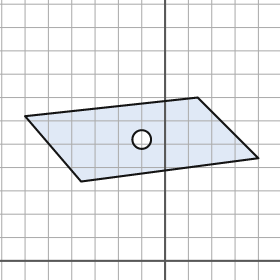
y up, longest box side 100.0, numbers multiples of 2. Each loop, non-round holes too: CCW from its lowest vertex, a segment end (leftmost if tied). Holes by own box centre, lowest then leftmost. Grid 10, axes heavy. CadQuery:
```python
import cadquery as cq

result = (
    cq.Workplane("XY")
    .moveTo(-36.0, 34.0)
    .lineTo(40.0, 44.0)
    .lineTo(14.0, 70.0)
    .lineTo(-60.0, 62.0)
    .close()
    .moveTo(-10.0, 52.0)
    .circle(4.0)
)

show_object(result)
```